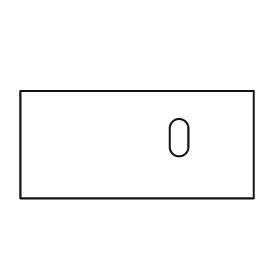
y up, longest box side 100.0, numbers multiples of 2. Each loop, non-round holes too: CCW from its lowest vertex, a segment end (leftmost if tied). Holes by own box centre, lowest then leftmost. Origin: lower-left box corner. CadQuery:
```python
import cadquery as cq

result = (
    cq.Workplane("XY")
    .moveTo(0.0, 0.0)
    .lineTo(100.0, 0.0)
    .lineTo(100.0, 46.0)
    .lineTo(0.0, 46.0)
    .close()
    .moveTo(64.0, 22.0)
    .threePointArc((68.0, 18.0), (72.0, 22.0))
    .lineTo(72.0, 30.0)
    .threePointArc((68.0, 34.0), (64.0, 30.0))
    .close()
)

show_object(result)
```